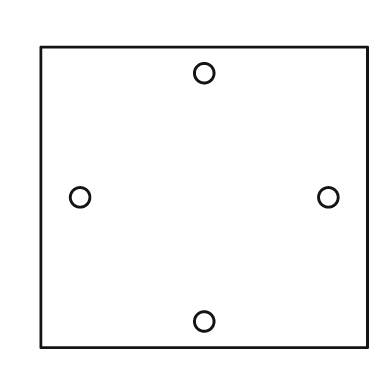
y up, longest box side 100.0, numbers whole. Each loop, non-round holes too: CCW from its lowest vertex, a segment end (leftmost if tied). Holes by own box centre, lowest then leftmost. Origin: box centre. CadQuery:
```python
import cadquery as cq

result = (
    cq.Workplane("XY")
    .moveTo(-50.0, -46.0)
    .lineTo(50.0, -46.0)
    .lineTo(50.0, 46.0)
    .lineTo(-50.0, 46.0)
    .close()
    .moveTo(0.0, -38.0)
    .circle(3.0)
    .moveTo(-38.0, 0.0)
    .circle(3.0)
    .moveTo(38.0, 0.0)
    .circle(3.0)
    .moveTo(0.0, 38.0)
    .circle(3.0)
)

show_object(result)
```